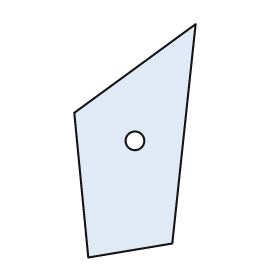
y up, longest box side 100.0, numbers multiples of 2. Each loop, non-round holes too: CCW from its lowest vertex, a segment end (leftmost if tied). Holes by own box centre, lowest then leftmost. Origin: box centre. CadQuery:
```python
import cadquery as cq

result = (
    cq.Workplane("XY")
    .moveTo(-20.0, -50.0)
    .lineTo(16.0, -44.0)
    .lineTo(26.0, 50.0)
    .lineTo(-26.0, 12.0)
    .close()
    .moveTo(0.0, 0.0)
    .circle(4.0)
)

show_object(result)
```